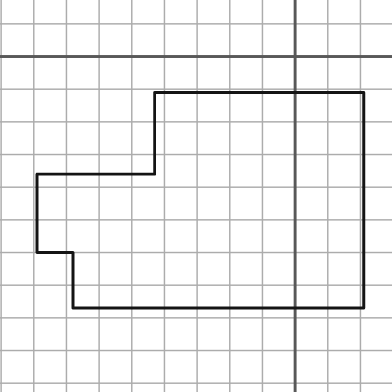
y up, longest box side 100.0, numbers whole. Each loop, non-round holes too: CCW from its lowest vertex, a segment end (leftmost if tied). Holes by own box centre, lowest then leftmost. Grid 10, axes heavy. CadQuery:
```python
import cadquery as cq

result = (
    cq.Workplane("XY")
    .moveTo(-68.0, -77.0)
    .lineTo(21.0, -77.0)
    .lineTo(21.0, -11.0)
    .lineTo(-43.0, -11.0)
    .lineTo(-43.0, -36.0)
    .lineTo(-79.0, -36.0)
    .lineTo(-79.0, -60.0)
    .lineTo(-68.0, -60.0)
    .close()
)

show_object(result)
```